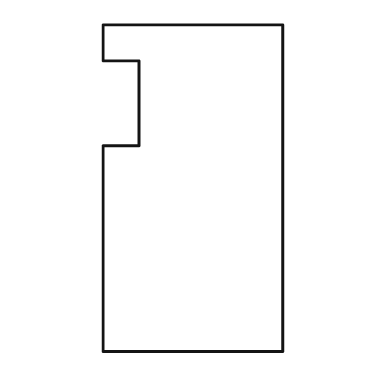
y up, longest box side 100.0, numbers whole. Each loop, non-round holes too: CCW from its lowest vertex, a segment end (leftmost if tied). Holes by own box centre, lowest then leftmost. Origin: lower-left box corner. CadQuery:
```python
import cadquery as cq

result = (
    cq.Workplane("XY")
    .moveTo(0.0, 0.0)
    .lineTo(55.0, 0.0)
    .lineTo(55.0, 100.0)
    .lineTo(0.0, 100.0)
    .lineTo(0.0, 89.0)
    .lineTo(11.0, 89.0)
    .lineTo(11.0, 63.0)
    .lineTo(0.0, 63.0)
    .close()
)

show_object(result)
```